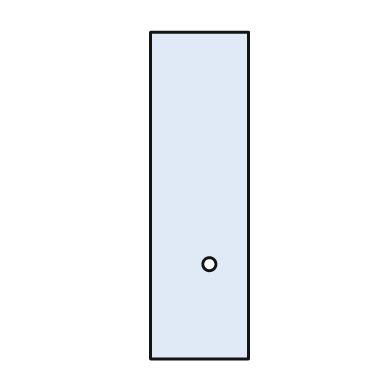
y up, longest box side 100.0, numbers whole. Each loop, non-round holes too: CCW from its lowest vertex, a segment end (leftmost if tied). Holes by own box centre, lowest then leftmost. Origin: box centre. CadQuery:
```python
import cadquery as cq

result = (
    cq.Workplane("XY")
    .moveTo(-15.0, -50.0)
    .lineTo(15.0, -50.0)
    .lineTo(15.0, 50.0)
    .lineTo(-15.0, 50.0)
    .close()
    .moveTo(3.0, -21.0)
    .circle(2.0)
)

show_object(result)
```